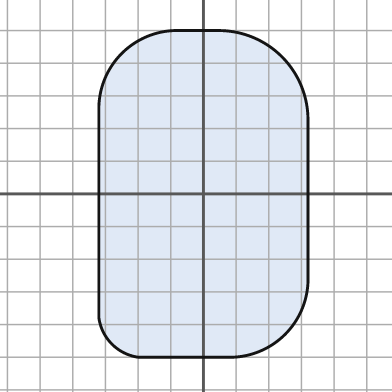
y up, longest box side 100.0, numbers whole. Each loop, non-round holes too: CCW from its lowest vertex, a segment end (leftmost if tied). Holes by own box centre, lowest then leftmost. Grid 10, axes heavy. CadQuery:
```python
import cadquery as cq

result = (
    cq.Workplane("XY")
    .moveTo(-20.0, -50.0)
    .lineTo(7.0, -50.0)
    .threePointArc((25.0, -43.0), (32.0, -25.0))
    .lineTo(32.0, 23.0)
    .threePointArc((24.0, 42.0), (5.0, 50.0))
    .lineTo(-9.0, 50.0)
    .threePointArc((-25.0, 43.0), (-32.0, 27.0))
    .lineTo(-32.0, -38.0)
    .threePointArc((-28.0, -46.0), (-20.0, -50.0))
    .close()
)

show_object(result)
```